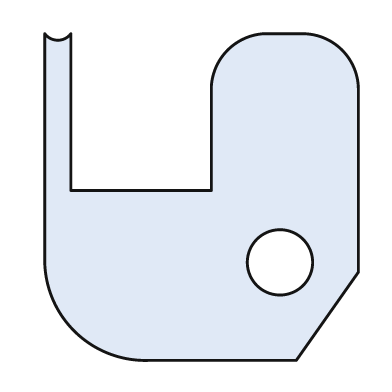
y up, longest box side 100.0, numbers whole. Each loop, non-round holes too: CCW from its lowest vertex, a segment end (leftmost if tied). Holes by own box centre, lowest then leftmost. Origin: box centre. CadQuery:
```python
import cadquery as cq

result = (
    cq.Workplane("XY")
    .moveTo(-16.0, -50.0)
    .lineTo(29.0, -50.0)
    .lineTo(48.0, -23.0)
    .lineTo(48.0, 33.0)
    .threePointArc((43.0, 45.0), (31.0, 50.0))
    .lineTo(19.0, 50.0)
    .threePointArc((8.0, 45.0), (3.0, 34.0))
    .lineTo(3.0, 2.0)
    .lineTo(-40.0, 2.0)
    .lineTo(-40.0, 50.0)
    .threePointArc((-44.0, 48.0), (-48.0, 50.0))
    .lineTo(-48.0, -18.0)
    .threePointArc((-39.0, -41.0), (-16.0, -50.0))
    .close()
    .moveTo(24.0, -20.0)
    .circle(10.0)
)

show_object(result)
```